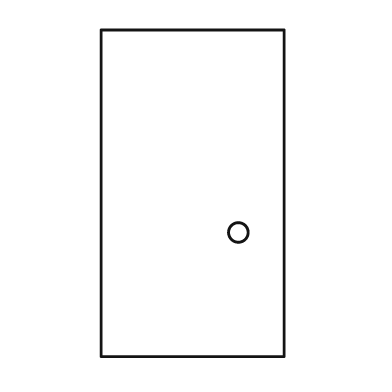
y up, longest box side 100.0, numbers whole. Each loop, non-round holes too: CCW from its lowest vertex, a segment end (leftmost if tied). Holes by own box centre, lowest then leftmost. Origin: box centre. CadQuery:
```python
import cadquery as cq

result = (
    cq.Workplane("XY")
    .moveTo(-28.0, -50.0)
    .lineTo(28.0, -50.0)
    .lineTo(28.0, 50.0)
    .lineTo(-28.0, 50.0)
    .close()
    .moveTo(14.0, -12.0)
    .circle(3.0)
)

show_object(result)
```